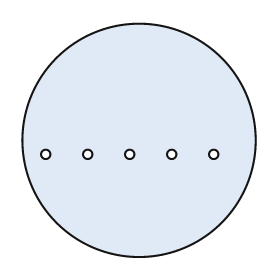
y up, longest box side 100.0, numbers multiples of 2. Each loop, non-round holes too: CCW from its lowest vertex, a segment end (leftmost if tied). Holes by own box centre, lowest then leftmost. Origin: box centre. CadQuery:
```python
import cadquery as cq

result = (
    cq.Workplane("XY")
    .moveTo(0.0, 0.0)
    .circle(50.0)
    .moveTo(-40.0, -6.0)
    .circle(2.0)
    .moveTo(-22.0, -6.0)
    .circle(2.0)
    .moveTo(-4.0, -6.0)
    .circle(2.0)
    .moveTo(14.0, -6.0)
    .circle(2.0)
    .moveTo(32.0, -6.0)
    .circle(2.0)
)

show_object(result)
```